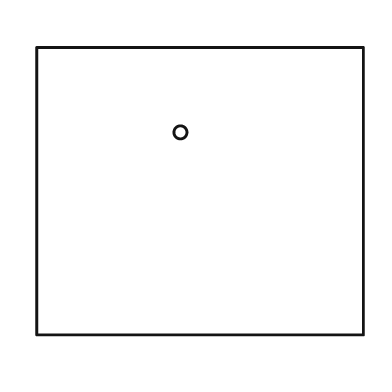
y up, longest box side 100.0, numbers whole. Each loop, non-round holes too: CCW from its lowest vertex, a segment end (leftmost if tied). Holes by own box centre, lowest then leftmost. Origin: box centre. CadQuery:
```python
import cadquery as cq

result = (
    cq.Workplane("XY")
    .moveTo(-50.0, -44.0)
    .lineTo(50.0, -44.0)
    .lineTo(50.0, 44.0)
    .lineTo(-50.0, 44.0)
    .close()
    .moveTo(-6.0, 18.0)
    .circle(2.0)
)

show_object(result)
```